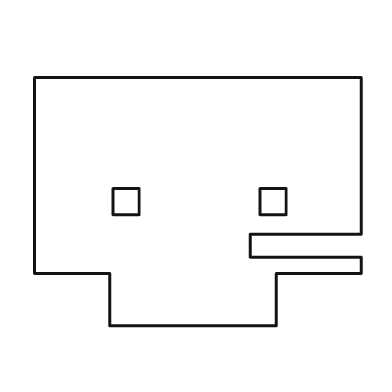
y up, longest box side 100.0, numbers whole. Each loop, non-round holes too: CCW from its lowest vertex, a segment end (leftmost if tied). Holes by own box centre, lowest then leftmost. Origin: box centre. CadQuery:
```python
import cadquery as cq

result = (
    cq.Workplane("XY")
    .moveTo(-27.0, -38.0)
    .lineTo(24.0, -38.0)
    .lineTo(24.0, -22.0)
    .lineTo(50.0, -22.0)
    .lineTo(50.0, -17.0)
    .lineTo(16.0, -17.0)
    .lineTo(16.0, -10.0)
    .lineTo(50.0, -10.0)
    .lineTo(50.0, 38.0)
    .lineTo(-50.0, 38.0)
    .lineTo(-50.0, -22.0)
    .lineTo(-27.0, -22.0)
    .close()
    .moveTo(-26.0, -4.0)
    .lineTo(-18.0, -4.0)
    .lineTo(-18.0, 4.0)
    .lineTo(-26.0, 4.0)
    .close()
    .moveTo(19.0, -4.0)
    .lineTo(27.0, -4.0)
    .lineTo(27.0, 4.0)
    .lineTo(19.0, 4.0)
    .close()
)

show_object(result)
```